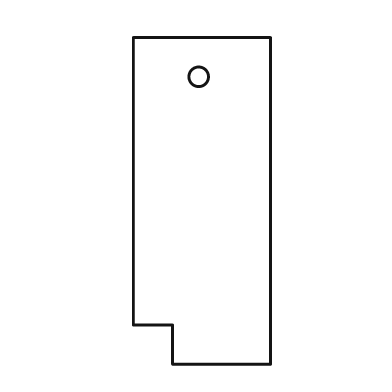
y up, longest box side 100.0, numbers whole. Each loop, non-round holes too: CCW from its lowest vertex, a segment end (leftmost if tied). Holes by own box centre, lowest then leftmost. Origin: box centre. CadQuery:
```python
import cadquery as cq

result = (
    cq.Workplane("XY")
    .moveTo(-9.0, -50.0)
    .lineTo(21.0, -50.0)
    .lineTo(21.0, 50.0)
    .lineTo(-21.0, 50.0)
    .lineTo(-21.0, -38.0)
    .lineTo(-9.0, -38.0)
    .close()
    .moveTo(-1.0, 38.0)
    .circle(3.0)
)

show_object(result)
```